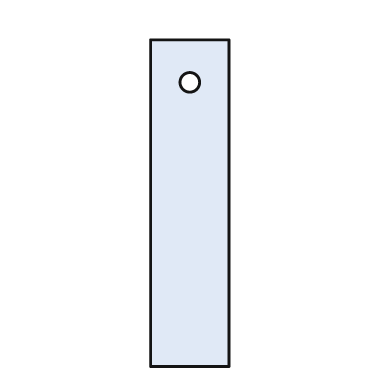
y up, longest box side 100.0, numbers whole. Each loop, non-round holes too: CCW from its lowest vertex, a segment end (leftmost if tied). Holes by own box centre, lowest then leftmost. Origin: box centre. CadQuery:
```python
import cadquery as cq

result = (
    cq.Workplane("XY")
    .moveTo(-12.0, -50.0)
    .lineTo(12.0, -50.0)
    .lineTo(12.0, 50.0)
    .lineTo(-12.0, 50.0)
    .close()
    .moveTo(0.0, 37.0)
    .circle(3.0)
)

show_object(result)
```